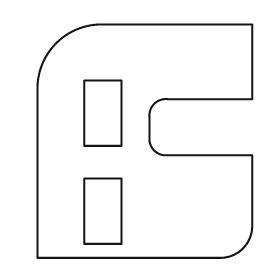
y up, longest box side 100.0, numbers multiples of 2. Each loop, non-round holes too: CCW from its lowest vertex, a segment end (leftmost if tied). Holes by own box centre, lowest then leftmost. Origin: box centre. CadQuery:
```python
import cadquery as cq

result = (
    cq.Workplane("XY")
    .moveTo(-46.0, -50.0)
    .lineTo(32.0, -50.0)
    .threePointArc((42.0, -46.0), (46.0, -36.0))
    .lineTo(46.0, -6.0)
    .lineTo(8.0, -6.0)
    .threePointArc((4.0, -4.0), (2.0, 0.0))
    .lineTo(2.0, 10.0)
    .threePointArc((4.0, 16.0), (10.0, 18.0))
    .lineTo(46.0, 18.0)
    .lineTo(46.0, 50.0)
    .lineTo(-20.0, 50.0)
    .threePointArc((-38.0, 42.0), (-46.0, 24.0))
    .close()
    .moveTo(-26.0, -44.0)
    .lineTo(-10.0, -44.0)
    .lineTo(-10.0, -16.0)
    .lineTo(-26.0, -16.0)
    .close()
    .moveTo(-26.0, -2.0)
    .lineTo(-10.0, -2.0)
    .lineTo(-10.0, 26.0)
    .lineTo(-26.0, 26.0)
    .close()
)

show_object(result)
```